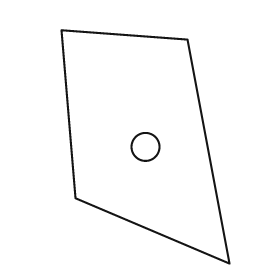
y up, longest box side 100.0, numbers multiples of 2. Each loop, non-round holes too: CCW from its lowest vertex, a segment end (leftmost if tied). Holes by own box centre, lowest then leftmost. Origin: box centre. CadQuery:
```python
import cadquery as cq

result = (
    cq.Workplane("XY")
    .moveTo(36.0, -50.0)
    .lineTo(18.0, 46.0)
    .lineTo(-36.0, 50.0)
    .lineTo(-30.0, -22.0)
    .close()
    .moveTo(0.0, 0.0)
    .circle(6.0)
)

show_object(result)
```